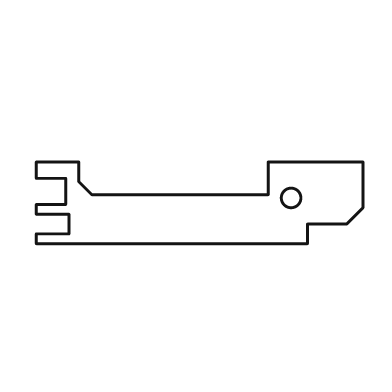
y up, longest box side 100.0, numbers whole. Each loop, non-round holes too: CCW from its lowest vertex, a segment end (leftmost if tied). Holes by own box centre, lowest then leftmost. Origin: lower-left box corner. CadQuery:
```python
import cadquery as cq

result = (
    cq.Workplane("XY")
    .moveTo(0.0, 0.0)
    .lineTo(83.0, 0.0)
    .lineTo(83.0, 6.0)
    .lineTo(95.0, 6.0)
    .lineTo(100.0, 11.0)
    .lineTo(100.0, 25.0)
    .lineTo(71.0, 25.0)
    .lineTo(71.0, 15.0)
    .lineTo(17.0, 15.0)
    .lineTo(13.0, 19.0)
    .lineTo(13.0, 25.0)
    .lineTo(0.0, 25.0)
    .lineTo(0.0, 20.0)
    .lineTo(9.0, 20.0)
    .lineTo(9.0, 12.0)
    .lineTo(0.0, 12.0)
    .lineTo(0.0, 9.0)
    .lineTo(10.0, 9.0)
    .lineTo(10.0, 3.0)
    .lineTo(0.0, 3.0)
    .close()
    .moveTo(78.0, 14.0)
    .circle(3.0)
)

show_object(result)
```